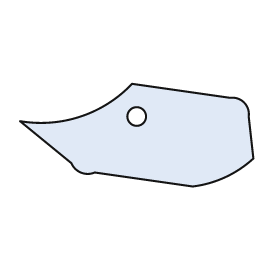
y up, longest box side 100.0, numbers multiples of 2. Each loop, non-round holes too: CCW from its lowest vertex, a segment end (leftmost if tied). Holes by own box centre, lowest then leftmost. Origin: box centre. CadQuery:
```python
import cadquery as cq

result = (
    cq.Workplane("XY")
    .moveTo(24.0, -22.0)
    .threePointArc((38.0, -18.0), (50.0, -10.0))
    .lineTo(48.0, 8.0)
    .threePointArc((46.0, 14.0), (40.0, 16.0))
    .lineTo(-2.0, 22.0)
    .threePointArc((-24.0, 8.0), (-50.0, 6.0))
    .lineTo(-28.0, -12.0)
    .threePointArc((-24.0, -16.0), (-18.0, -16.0))
    .close()
    .moveTo(0.0, 8.0)
    .circle(4.0)
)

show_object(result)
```